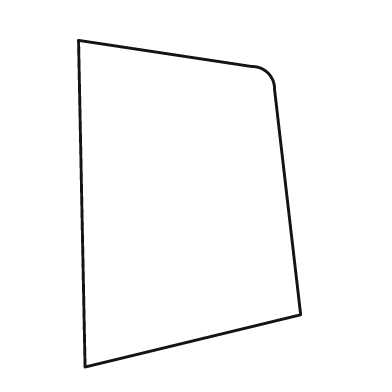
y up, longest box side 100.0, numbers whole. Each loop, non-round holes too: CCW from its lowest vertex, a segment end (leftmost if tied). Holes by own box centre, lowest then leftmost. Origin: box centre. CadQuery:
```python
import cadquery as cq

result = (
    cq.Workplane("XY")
    .moveTo(-32.0, -50.0)
    .lineTo(34.0, -34.0)
    .lineTo(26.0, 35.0)
    .threePointArc((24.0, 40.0), (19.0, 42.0))
    .lineTo(-34.0, 50.0)
    .close()
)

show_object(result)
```